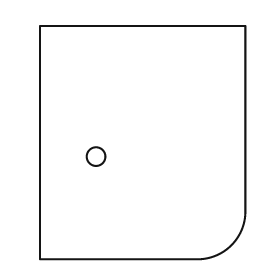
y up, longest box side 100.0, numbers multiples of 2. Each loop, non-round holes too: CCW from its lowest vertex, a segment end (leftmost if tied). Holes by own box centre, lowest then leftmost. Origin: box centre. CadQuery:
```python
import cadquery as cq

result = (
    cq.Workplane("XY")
    .moveTo(-44.0, -50.0)
    .lineTo(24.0, -50.0)
    .threePointArc((38.0, -44.0), (44.0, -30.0))
    .lineTo(44.0, 50.0)
    .lineTo(-44.0, 50.0)
    .close()
    .moveTo(-20.0, -6.0)
    .circle(4.0)
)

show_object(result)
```